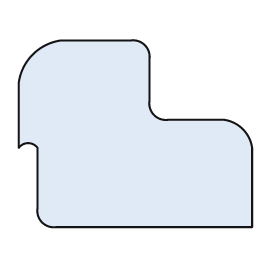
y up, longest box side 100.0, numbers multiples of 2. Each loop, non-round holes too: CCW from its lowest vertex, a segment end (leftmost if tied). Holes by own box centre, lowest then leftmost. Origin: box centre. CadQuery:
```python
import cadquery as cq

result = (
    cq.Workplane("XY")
    .moveTo(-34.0, -40.0)
    .lineTo(50.0, -40.0)
    .lineTo(50.0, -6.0)
    .threePointArc((46.0, 2.0), (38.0, 6.0))
    .lineTo(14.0, 6.0)
    .threePointArc((8.0, 8.0), (6.0, 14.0))
    .lineTo(6.0, 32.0)
    .threePointArc((4.0, 38.0), (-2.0, 40.0))
    .lineTo(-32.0, 40.0)
    .threePointArc((-44.0, 34.0), (-50.0, 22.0))
    .lineTo(-50.0, -6.0)
    .threePointArc((-46.0, -4.0), (-42.0, -6.0))
    .lineTo(-42.0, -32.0)
    .threePointArc((-40.0, -38.0), (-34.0, -40.0))
    .close()
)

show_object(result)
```